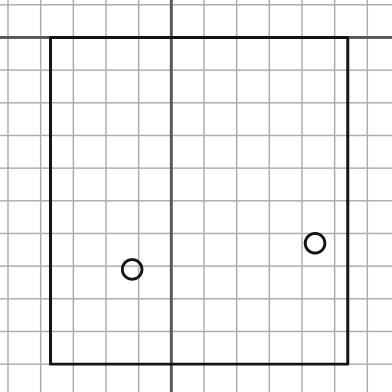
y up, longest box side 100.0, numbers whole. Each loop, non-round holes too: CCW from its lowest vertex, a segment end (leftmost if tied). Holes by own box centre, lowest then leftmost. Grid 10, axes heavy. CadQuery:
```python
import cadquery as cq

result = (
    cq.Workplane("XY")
    .moveTo(-37.0, -100.0)
    .lineTo(54.0, -100.0)
    .lineTo(54.0, 0.0)
    .lineTo(-37.0, 0.0)
    .close()
    .moveTo(-12.0, -71.0)
    .circle(3.0)
    .moveTo(44.0, -63.0)
    .circle(3.0)
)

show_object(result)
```